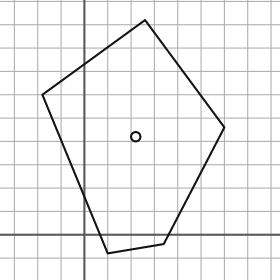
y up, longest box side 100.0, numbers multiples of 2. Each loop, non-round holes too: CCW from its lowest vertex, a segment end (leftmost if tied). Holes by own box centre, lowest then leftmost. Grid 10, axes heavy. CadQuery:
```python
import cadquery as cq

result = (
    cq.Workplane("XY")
    .moveTo(10.0, -8.0)
    .lineTo(34.0, -4.0)
    .lineTo(60.0, 46.0)
    .lineTo(26.0, 92.0)
    .lineTo(-18.0, 60.0)
    .close()
    .moveTo(22.0, 42.0)
    .circle(2.0)
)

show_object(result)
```